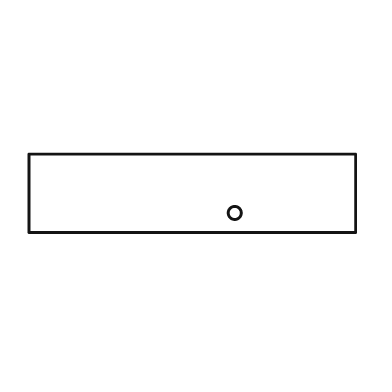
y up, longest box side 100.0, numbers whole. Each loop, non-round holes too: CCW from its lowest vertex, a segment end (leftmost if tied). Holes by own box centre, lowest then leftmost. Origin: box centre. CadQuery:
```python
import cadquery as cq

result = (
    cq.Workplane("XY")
    .moveTo(-50.0, -12.0)
    .lineTo(50.0, -12.0)
    .lineTo(50.0, 12.0)
    .lineTo(-50.0, 12.0)
    .close()
    .moveTo(13.0, -6.0)
    .circle(2.0)
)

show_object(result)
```